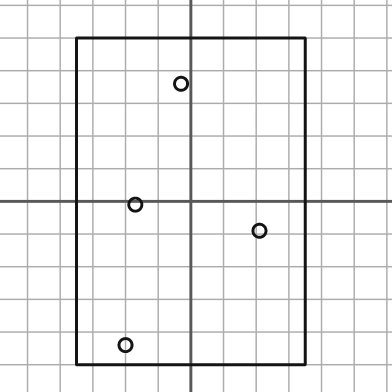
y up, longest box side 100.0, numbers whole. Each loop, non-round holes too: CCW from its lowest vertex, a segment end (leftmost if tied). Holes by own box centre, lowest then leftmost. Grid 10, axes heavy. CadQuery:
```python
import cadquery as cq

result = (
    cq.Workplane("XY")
    .moveTo(-35.0, -50.0)
    .lineTo(35.0, -50.0)
    .lineTo(35.0, 50.0)
    .lineTo(-35.0, 50.0)
    .close()
    .moveTo(-20.0, -44.0)
    .circle(2.0)
    .moveTo(21.0, -9.0)
    .circle(2.0)
    .moveTo(-17.0, -1.0)
    .circle(2.0)
    .moveTo(-3.0, 36.0)
    .circle(2.0)
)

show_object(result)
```